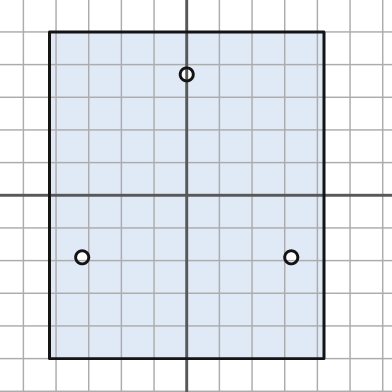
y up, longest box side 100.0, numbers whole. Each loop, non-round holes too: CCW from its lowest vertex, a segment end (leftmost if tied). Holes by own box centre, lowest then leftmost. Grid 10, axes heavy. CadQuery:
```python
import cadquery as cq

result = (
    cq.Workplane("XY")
    .moveTo(-42.0, -50.0)
    .lineTo(42.0, -50.0)
    .lineTo(42.0, 50.0)
    .lineTo(-42.0, 50.0)
    .close()
    .moveTo(-32.0, -19.0)
    .circle(2.0)
    .moveTo(32.0, -19.0)
    .circle(2.0)
    .moveTo(0.0, 37.0)
    .circle(2.0)
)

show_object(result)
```